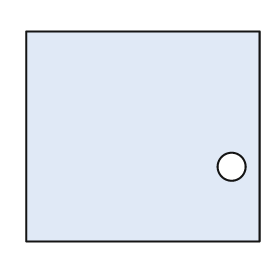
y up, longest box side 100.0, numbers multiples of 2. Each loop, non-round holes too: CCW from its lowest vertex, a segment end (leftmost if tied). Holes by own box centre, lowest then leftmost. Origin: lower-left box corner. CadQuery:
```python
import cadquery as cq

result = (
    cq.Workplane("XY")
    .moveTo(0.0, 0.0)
    .lineTo(100.0, 0.0)
    .lineTo(100.0, 90.0)
    .lineTo(0.0, 90.0)
    .close()
    .moveTo(88.0, 32.0)
    .circle(6.0)
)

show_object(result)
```